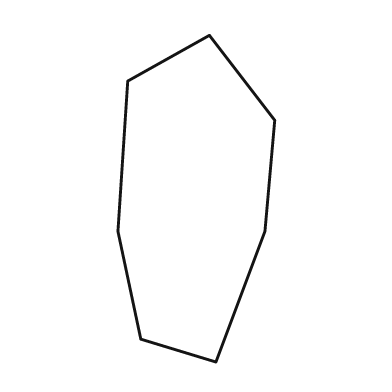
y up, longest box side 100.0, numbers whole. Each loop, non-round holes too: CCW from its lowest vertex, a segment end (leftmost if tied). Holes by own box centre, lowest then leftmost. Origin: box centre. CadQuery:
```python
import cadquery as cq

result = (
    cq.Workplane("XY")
    .moveTo(6.0, -50.0)
    .lineTo(21.0, -10.0)
    .lineTo(24.0, 24.0)
    .lineTo(4.0, 50.0)
    .lineTo(-21.0, 36.0)
    .lineTo(-24.0, -10.0)
    .lineTo(-17.0, -43.0)
    .close()
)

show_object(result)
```